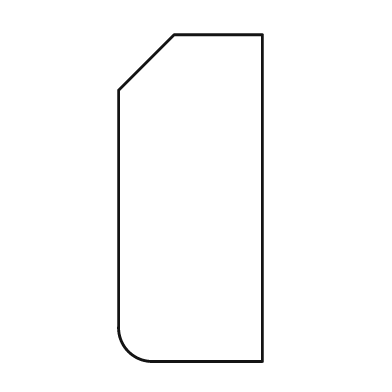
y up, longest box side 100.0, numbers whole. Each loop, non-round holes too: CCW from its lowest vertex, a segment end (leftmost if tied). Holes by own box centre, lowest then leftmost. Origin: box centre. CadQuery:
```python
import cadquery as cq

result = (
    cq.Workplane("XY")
    .moveTo(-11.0, -50.0)
    .lineTo(22.0, -50.0)
    .lineTo(22.0, 50.0)
    .lineTo(-5.0, 50.0)
    .lineTo(-22.0, 33.0)
    .lineTo(-22.0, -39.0)
    .threePointArc((-19.0, -47.0), (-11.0, -50.0))
    .close()
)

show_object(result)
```